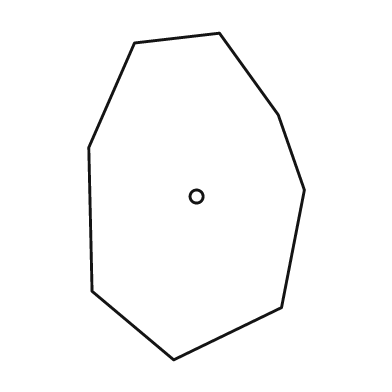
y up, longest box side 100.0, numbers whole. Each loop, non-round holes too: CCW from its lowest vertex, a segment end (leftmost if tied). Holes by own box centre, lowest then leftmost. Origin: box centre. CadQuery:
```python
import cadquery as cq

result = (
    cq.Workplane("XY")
    .moveTo(-7.0, -50.0)
    .lineTo(26.0, -34.0)
    .lineTo(33.0, 2.0)
    .lineTo(25.0, 25.0)
    .lineTo(7.0, 50.0)
    .lineTo(-19.0, 47.0)
    .lineTo(-33.0, 15.0)
    .lineTo(-32.0, -29.0)
    .close()
    .moveTo(0.0, 0.0)
    .circle(2.0)
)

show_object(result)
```